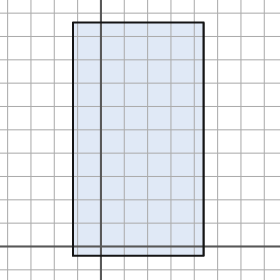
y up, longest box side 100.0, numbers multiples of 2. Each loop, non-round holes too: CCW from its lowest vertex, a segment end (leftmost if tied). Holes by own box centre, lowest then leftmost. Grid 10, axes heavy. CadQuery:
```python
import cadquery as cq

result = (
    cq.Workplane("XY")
    .moveTo(-12.0, -4.0)
    .lineTo(44.0, -4.0)
    .lineTo(44.0, 96.0)
    .lineTo(-12.0, 96.0)
    .close()
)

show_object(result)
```